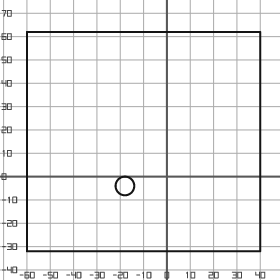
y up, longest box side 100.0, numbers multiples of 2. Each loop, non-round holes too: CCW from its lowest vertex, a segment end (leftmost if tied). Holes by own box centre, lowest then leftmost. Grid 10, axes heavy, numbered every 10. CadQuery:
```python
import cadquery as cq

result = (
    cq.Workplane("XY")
    .moveTo(-60.0, -32.0)
    .lineTo(40.0, -32.0)
    .lineTo(40.0, 62.0)
    .lineTo(-60.0, 62.0)
    .close()
    .moveTo(-18.0, -4.0)
    .circle(4.0)
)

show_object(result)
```